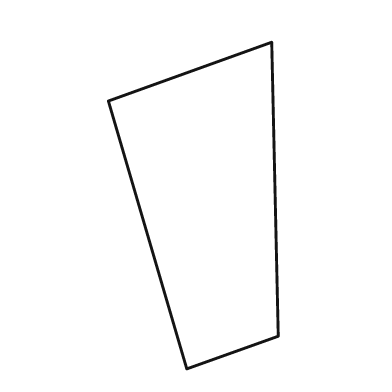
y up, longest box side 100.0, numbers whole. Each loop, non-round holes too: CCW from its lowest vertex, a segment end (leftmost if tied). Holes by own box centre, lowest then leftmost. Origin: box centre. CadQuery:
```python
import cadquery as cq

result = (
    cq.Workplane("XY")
    .moveTo(-2.0, -50.0)
    .lineTo(26.0, -40.0)
    .lineTo(24.0, 50.0)
    .lineTo(-26.0, 32.0)
    .close()
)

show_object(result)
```